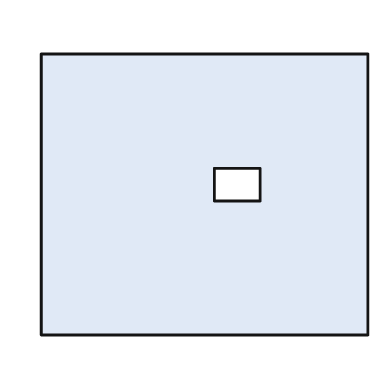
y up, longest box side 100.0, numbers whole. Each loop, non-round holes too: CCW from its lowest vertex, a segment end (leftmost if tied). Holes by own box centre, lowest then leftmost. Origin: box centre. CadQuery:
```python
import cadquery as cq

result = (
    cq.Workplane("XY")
    .moveTo(-50.0, -43.0)
    .lineTo(50.0, -43.0)
    .lineTo(50.0, 43.0)
    .lineTo(-50.0, 43.0)
    .close()
    .moveTo(3.0, -2.0)
    .lineTo(17.0, -2.0)
    .lineTo(17.0, 8.0)
    .lineTo(3.0, 8.0)
    .close()
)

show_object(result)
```